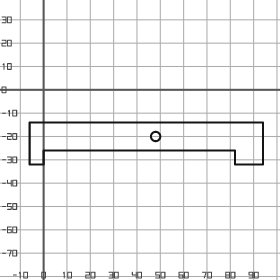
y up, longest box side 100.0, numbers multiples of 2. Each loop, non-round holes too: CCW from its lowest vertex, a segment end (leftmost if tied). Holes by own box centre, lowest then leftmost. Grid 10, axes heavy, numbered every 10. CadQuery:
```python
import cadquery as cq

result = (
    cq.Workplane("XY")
    .moveTo(-6.0, -32.0)
    .lineTo(0.0, -32.0)
    .lineTo(0.0, -26.0)
    .lineTo(82.0, -26.0)
    .lineTo(82.0, -32.0)
    .lineTo(94.0, -32.0)
    .lineTo(94.0, -14.0)
    .lineTo(-6.0, -14.0)
    .close()
    .moveTo(48.0, -20.0)
    .circle(2.0)
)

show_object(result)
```